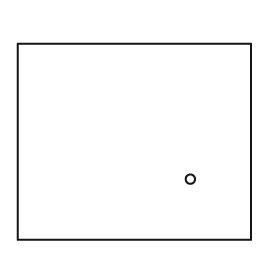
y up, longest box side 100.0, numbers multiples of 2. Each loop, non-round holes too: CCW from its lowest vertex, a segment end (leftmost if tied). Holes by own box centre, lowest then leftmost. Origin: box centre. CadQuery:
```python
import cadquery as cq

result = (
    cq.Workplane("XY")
    .moveTo(-50.0, -42.0)
    .lineTo(50.0, -42.0)
    .lineTo(50.0, 42.0)
    .lineTo(-50.0, 42.0)
    .close()
    .moveTo(24.0, -16.0)
    .circle(2.0)
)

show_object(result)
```